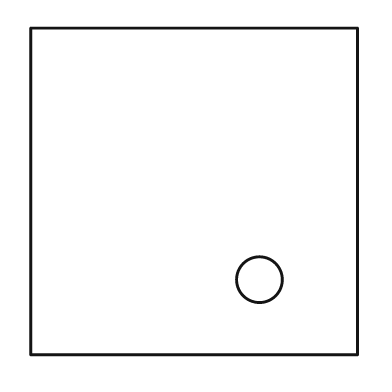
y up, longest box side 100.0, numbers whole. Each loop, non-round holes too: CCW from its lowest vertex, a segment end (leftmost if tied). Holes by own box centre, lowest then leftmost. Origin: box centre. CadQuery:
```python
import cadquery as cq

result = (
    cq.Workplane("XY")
    .moveTo(-50.0, -50.0)
    .lineTo(50.0, -50.0)
    .lineTo(50.0, 50.0)
    .lineTo(-50.0, 50.0)
    .close()
    .moveTo(20.0, -27.0)
    .circle(7.0)
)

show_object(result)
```